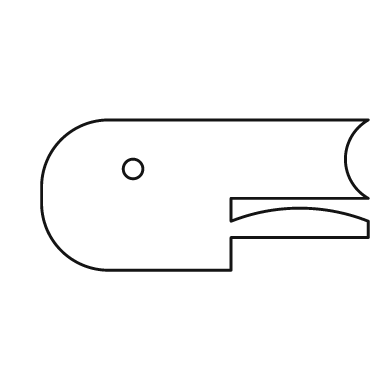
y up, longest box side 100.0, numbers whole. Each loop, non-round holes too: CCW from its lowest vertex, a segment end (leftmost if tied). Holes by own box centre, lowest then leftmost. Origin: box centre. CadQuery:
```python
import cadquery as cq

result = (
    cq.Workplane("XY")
    .moveTo(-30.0, -23.0)
    .lineTo(8.0, -23.0)
    .lineTo(8.0, -13.0)
    .lineTo(50.0, -13.0)
    .lineTo(50.0, -8.0)
    .threePointArc((29.0, -4.0), (8.0, -8.0))
    .lineTo(8.0, -1.0)
    .lineTo(50.0, -1.0)
    .threePointArc((43.0, 11.0), (50.0, 23.0))
    .lineTo(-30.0, 23.0)
    .threePointArc((-44.0, 17.0), (-50.0, 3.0))
    .lineTo(-50.0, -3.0)
    .threePointArc((-44.0, -17.0), (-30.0, -23.0))
    .close()
    .moveTo(-22.0, 8.0)
    .circle(3.0)
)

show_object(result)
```